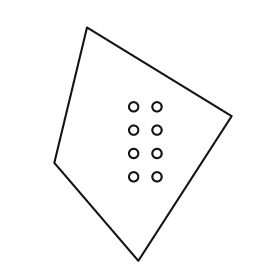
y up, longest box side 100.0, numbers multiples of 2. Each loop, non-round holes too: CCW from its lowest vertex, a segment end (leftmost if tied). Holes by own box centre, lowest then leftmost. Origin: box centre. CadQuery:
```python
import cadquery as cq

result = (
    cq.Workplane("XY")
    .moveTo(-2.0, -50.0)
    .lineTo(38.0, 12.0)
    .lineTo(-24.0, 50.0)
    .lineTo(-38.0, -8.0)
    .close()
    .moveTo(-4.0, -14.0)
    .circle(2.0)
    .moveTo(6.0, -14.0)
    .circle(2.0)
    .moveTo(-4.0, -4.0)
    .circle(2.0)
    .moveTo(6.0, -4.0)
    .circle(2.0)
    .moveTo(-4.0, 6.0)
    .circle(2.0)
    .moveTo(6.0, 6.0)
    .circle(2.0)
    .moveTo(-4.0, 16.0)
    .circle(2.0)
    .moveTo(6.0, 16.0)
    .circle(2.0)
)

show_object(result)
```